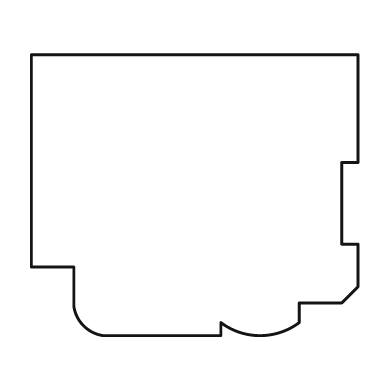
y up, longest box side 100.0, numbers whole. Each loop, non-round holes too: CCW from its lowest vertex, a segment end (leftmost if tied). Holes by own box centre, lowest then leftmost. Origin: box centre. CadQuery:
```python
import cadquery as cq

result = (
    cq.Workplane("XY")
    .moveTo(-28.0, -43.0)
    .lineTo(8.0, -43.0)
    .lineTo(8.0, -39.0)
    .threePointArc((20.0, -43.0), (32.0, -39.0))
    .lineTo(32.0, -33.0)
    .lineTo(45.0, -33.0)
    .lineTo(50.0, -28.0)
    .lineTo(50.0, -15.0)
    .lineTo(45.0, -15.0)
    .lineTo(45.0, 10.0)
    .lineTo(50.0, 10.0)
    .lineTo(50.0, 43.0)
    .lineTo(-50.0, 43.0)
    .lineTo(-50.0, -22.0)
    .lineTo(-37.0, -22.0)
    .lineTo(-37.0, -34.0)
    .threePointArc((-34.0, -40.0), (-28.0, -43.0))
    .close()
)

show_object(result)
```